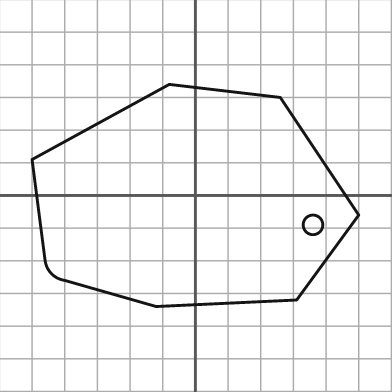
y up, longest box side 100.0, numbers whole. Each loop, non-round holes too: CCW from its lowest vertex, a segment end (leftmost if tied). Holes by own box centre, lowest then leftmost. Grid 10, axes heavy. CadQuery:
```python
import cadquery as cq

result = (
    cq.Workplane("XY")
    .moveTo(-12.0, -34.0)
    .lineTo(31.0, -32.0)
    .lineTo(50.0, -6.0)
    .lineTo(26.0, 30.0)
    .lineTo(-8.0, 34.0)
    .lineTo(-50.0, 11.0)
    .lineTo(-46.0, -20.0)
    .threePointArc((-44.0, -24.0), (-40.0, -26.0))
    .close()
    .moveTo(36.0, -9.0)
    .circle(3.0)
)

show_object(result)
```